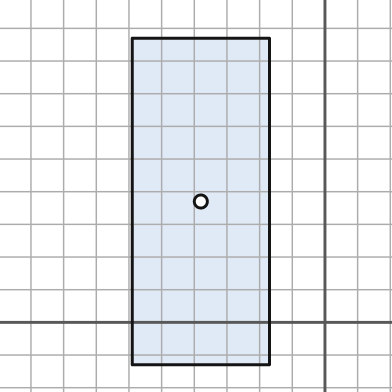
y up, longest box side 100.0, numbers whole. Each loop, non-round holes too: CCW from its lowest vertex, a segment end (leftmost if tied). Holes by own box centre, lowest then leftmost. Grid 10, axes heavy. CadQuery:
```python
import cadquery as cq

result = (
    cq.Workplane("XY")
    .moveTo(-59.0, -13.0)
    .lineTo(-17.0, -13.0)
    .lineTo(-17.0, 87.0)
    .lineTo(-59.0, 87.0)
    .close()
    .moveTo(-38.0, 37.0)
    .circle(2.0)
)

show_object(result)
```